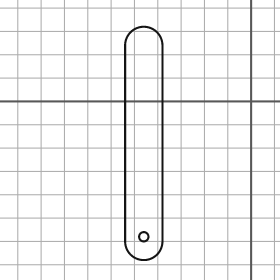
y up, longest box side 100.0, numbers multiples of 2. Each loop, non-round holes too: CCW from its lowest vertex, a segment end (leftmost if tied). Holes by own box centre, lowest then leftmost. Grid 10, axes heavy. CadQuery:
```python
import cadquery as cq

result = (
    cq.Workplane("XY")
    .moveTo(-54.0, -60.0)
    .threePointArc((-46.0, -68.0), (-38.0, -60.0))
    .lineTo(-38.0, 24.0)
    .threePointArc((-46.0, 32.0), (-54.0, 24.0))
    .close()
    .moveTo(-46.0, -58.0)
    .circle(2.0)
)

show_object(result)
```